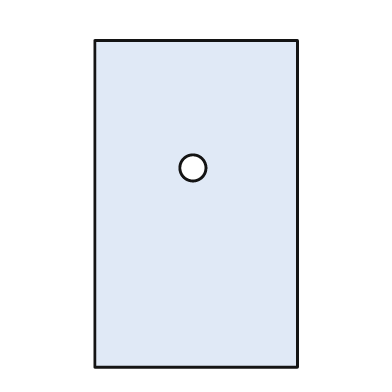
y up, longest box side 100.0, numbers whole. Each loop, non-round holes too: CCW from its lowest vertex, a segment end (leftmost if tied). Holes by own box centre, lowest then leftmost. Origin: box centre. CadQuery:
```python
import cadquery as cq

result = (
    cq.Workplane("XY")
    .moveTo(-31.0, -50.0)
    .lineTo(31.0, -50.0)
    .lineTo(31.0, 50.0)
    .lineTo(-31.0, 50.0)
    .close()
    .moveTo(-1.0, 11.0)
    .circle(4.0)
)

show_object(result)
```